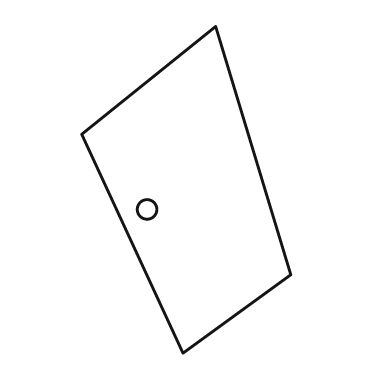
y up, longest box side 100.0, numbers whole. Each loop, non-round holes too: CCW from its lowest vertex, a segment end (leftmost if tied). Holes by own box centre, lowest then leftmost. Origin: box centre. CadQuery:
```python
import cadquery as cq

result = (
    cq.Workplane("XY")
    .moveTo(-1.0, -50.0)
    .lineTo(32.0, -26.0)
    .lineTo(9.0, 50.0)
    .lineTo(-32.0, 17.0)
    .close()
    .moveTo(-12.0, -6.0)
    .circle(3.0)
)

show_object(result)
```